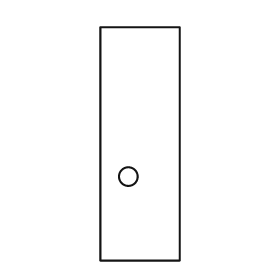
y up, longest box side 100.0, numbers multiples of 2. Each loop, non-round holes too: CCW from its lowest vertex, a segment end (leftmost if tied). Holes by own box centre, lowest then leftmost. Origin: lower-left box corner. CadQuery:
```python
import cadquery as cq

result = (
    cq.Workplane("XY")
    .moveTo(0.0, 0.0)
    .lineTo(34.0, 0.0)
    .lineTo(34.0, 100.0)
    .lineTo(0.0, 100.0)
    .close()
    .moveTo(12.0, 36.0)
    .circle(4.0)
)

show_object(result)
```